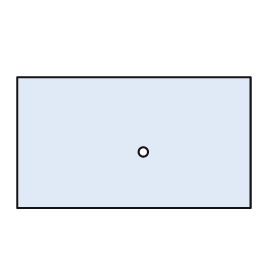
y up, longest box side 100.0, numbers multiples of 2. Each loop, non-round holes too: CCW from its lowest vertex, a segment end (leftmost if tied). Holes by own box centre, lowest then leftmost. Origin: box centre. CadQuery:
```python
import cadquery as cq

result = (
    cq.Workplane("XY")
    .moveTo(-50.0, -28.0)
    .lineTo(50.0, -28.0)
    .lineTo(50.0, 28.0)
    .lineTo(-50.0, 28.0)
    .close()
    .moveTo(4.0, -4.0)
    .circle(2.0)
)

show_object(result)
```